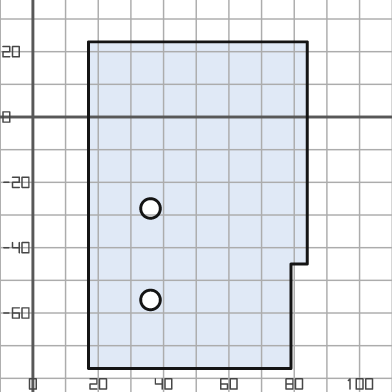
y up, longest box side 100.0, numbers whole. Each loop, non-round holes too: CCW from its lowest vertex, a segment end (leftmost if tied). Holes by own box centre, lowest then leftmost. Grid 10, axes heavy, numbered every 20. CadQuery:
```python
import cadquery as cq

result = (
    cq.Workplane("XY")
    .moveTo(17.0, -77.0)
    .lineTo(79.0, -77.0)
    .lineTo(79.0, -45.0)
    .lineTo(84.0, -45.0)
    .lineTo(84.0, 23.0)
    .lineTo(17.0, 23.0)
    .close()
    .moveTo(36.0, -56.0)
    .circle(3.0)
    .moveTo(36.0, -28.0)
    .circle(3.0)
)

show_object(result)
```